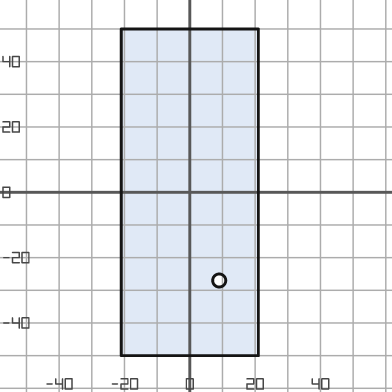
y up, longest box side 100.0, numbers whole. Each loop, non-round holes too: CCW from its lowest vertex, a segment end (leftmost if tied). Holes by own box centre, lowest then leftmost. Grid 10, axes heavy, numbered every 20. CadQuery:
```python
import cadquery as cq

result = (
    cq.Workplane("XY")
    .moveTo(-21.0, -50.0)
    .lineTo(21.0, -50.0)
    .lineTo(21.0, 50.0)
    .lineTo(-21.0, 50.0)
    .close()
    .moveTo(9.0, -27.0)
    .circle(2.0)
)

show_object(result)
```